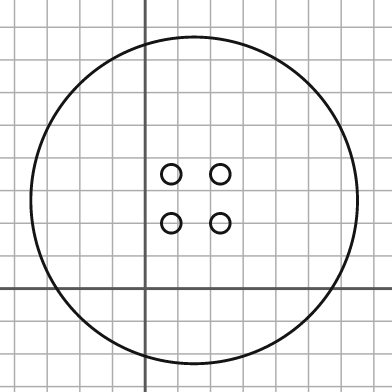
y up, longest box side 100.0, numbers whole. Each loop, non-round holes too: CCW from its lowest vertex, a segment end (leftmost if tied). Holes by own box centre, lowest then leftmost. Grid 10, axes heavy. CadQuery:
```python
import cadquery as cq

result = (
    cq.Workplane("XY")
    .moveTo(15.0, 27.0)
    .circle(50.0)
    .moveTo(8.0, 20.0)
    .circle(3.0)
    .moveTo(23.0, 20.0)
    .circle(3.0)
    .moveTo(8.0, 35.0)
    .circle(3.0)
    .moveTo(23.0, 35.0)
    .circle(3.0)
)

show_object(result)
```